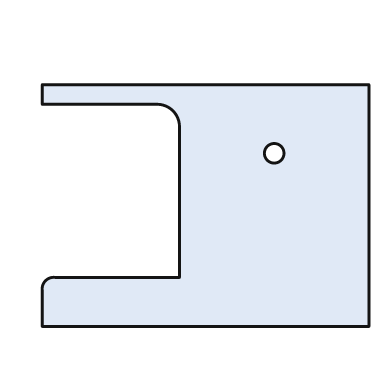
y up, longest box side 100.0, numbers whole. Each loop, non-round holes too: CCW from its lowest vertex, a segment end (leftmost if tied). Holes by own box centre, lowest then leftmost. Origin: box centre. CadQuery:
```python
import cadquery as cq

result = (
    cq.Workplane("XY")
    .moveTo(-50.0, -37.0)
    .lineTo(50.0, -37.0)
    .lineTo(50.0, 37.0)
    .lineTo(-50.0, 37.0)
    .lineTo(-50.0, 31.0)
    .lineTo(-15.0, 31.0)
    .threePointArc((-10.0, 29.0), (-8.0, 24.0))
    .lineTo(-8.0, -22.0)
    .lineTo(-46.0, -22.0)
    .threePointArc((-49.0, -23.0), (-50.0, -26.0))
    .close()
    .moveTo(21.0, 16.0)
    .circle(3.0)
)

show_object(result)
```